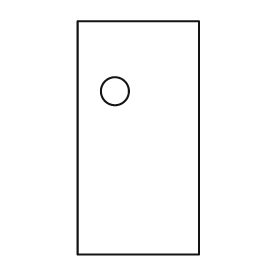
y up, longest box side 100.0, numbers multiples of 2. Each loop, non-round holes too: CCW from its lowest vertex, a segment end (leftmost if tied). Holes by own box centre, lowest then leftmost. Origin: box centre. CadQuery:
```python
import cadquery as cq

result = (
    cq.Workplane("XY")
    .moveTo(-26.0, -50.0)
    .lineTo(26.0, -50.0)
    .lineTo(26.0, 50.0)
    .lineTo(-26.0, 50.0)
    .close()
    .moveTo(-10.0, 20.0)
    .circle(6.0)
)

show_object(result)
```